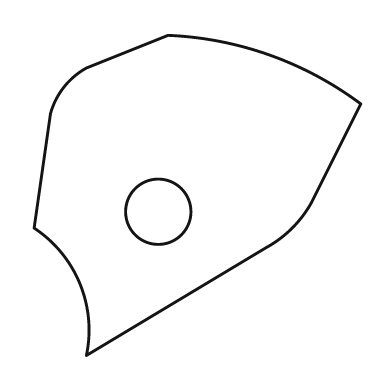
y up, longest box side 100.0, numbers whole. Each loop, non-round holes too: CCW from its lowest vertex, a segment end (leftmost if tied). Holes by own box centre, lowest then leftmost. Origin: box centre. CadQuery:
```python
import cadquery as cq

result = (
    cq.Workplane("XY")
    .moveTo(-34.0, -49.0)
    .lineTo(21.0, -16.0)
    .threePointArc((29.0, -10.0), (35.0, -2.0))
    .lineTo(50.0, 28.0)
    .threePointArc((22.0, 43.0), (-9.0, 49.0))
    .lineTo(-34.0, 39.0)
    .threePointArc((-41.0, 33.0), (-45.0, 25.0))
    .lineTo(-50.0, -10.0)
    .threePointArc((-36.0, -27.0), (-34.0, -49.0))
    .close()
    .moveTo(-12.0, -5.0)
    .circle(10.0)
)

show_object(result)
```